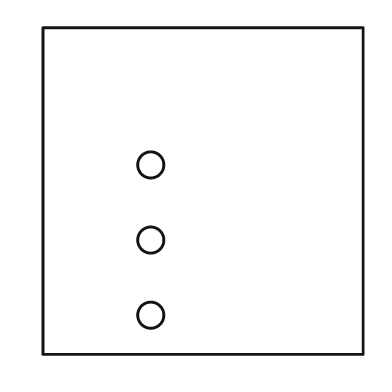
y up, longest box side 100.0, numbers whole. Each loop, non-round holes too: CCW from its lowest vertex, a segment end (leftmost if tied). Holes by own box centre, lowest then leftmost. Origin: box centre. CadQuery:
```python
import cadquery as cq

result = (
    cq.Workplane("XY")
    .moveTo(-49.0, -50.0)
    .lineTo(49.0, -50.0)
    .lineTo(49.0, 50.0)
    .lineTo(-49.0, 50.0)
    .close()
    .moveTo(-16.0, -38.0)
    .circle(4.0)
    .moveTo(-16.0, -15.0)
    .circle(4.0)
    .moveTo(-16.0, 8.0)
    .circle(4.0)
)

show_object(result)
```